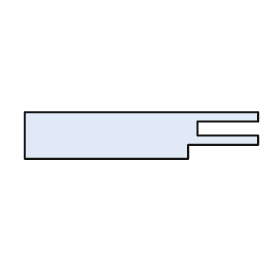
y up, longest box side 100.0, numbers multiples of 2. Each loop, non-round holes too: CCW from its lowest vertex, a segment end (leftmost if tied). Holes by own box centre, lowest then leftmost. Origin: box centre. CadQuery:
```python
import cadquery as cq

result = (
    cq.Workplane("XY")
    .moveTo(-50.0, -10.0)
    .lineTo(20.0, -10.0)
    .lineTo(20.0, -4.0)
    .lineTo(50.0, -4.0)
    .lineTo(50.0, 0.0)
    .lineTo(24.0, 0.0)
    .lineTo(24.0, 6.0)
    .lineTo(50.0, 6.0)
    .lineTo(50.0, 10.0)
    .lineTo(-50.0, 10.0)
    .close()
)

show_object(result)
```